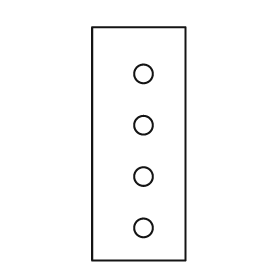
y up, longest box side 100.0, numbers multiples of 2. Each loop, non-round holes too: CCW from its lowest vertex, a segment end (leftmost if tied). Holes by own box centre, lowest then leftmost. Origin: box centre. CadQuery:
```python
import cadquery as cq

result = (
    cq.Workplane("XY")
    .moveTo(-20.0, -50.0)
    .lineTo(20.0, -50.0)
    .lineTo(20.0, 50.0)
    .lineTo(-20.0, 50.0)
    .close()
    .moveTo(2.0, -36.0)
    .circle(4.0)
    .moveTo(2.0, -14.0)
    .circle(4.0)
    .moveTo(2.0, 8.0)
    .circle(4.0)
    .moveTo(2.0, 30.0)
    .circle(4.0)
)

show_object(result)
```